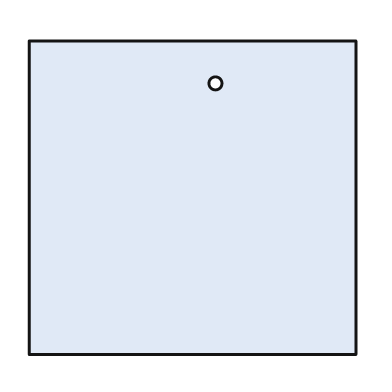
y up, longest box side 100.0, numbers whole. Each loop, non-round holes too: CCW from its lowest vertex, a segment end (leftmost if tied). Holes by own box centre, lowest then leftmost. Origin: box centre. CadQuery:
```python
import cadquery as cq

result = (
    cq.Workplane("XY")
    .moveTo(-50.0, -48.0)
    .lineTo(50.0, -48.0)
    .lineTo(50.0, 48.0)
    .lineTo(-50.0, 48.0)
    .close()
    .moveTo(7.0, 35.0)
    .circle(2.0)
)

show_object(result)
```